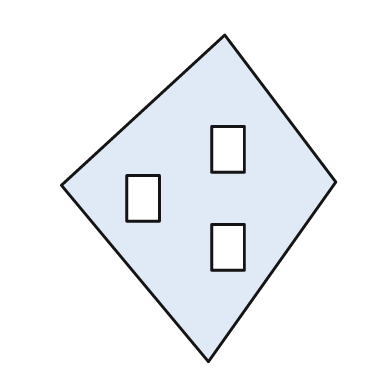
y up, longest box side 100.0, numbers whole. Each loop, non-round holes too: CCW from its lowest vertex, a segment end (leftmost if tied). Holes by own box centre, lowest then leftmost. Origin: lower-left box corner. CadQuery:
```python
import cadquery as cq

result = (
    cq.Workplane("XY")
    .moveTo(45.0, 0.0)
    .lineTo(84.0, 55.0)
    .lineTo(50.0, 100.0)
    .lineTo(0.0, 54.0)
    .close()
    .moveTo(46.0, 28.0)
    .lineTo(56.0, 28.0)
    .lineTo(56.0, 42.0)
    .lineTo(46.0, 42.0)
    .close()
    .moveTo(20.0, 43.0)
    .lineTo(30.0, 43.0)
    .lineTo(30.0, 57.0)
    .lineTo(20.0, 57.0)
    .close()
    .moveTo(46.0, 58.0)
    .lineTo(56.0, 58.0)
    .lineTo(56.0, 72.0)
    .lineTo(46.0, 72.0)
    .close()
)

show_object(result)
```